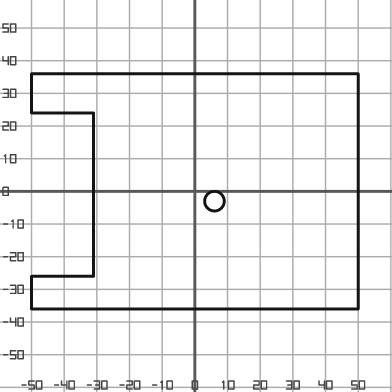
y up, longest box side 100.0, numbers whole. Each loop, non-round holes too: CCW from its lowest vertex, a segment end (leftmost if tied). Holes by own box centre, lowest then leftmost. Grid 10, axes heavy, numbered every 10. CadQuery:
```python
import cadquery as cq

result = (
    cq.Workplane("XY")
    .moveTo(-50.0, -36.0)
    .lineTo(50.0, -36.0)
    .lineTo(50.0, 36.0)
    .lineTo(-50.0, 36.0)
    .lineTo(-50.0, 24.0)
    .lineTo(-31.0, 24.0)
    .lineTo(-31.0, -26.0)
    .lineTo(-50.0, -26.0)
    .close()
    .moveTo(6.0, -3.0)
    .circle(3.0)
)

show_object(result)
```